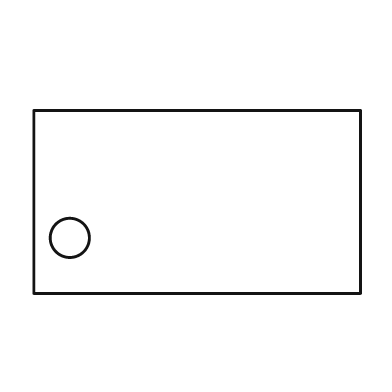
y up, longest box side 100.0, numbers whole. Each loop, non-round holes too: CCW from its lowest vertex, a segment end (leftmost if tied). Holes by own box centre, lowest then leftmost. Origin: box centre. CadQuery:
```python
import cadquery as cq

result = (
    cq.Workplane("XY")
    .moveTo(-50.0, -28.0)
    .lineTo(50.0, -28.0)
    .lineTo(50.0, 28.0)
    .lineTo(-50.0, 28.0)
    .close()
    .moveTo(-39.0, -11.0)
    .circle(6.0)
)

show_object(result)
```